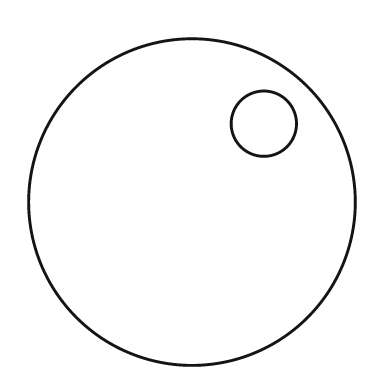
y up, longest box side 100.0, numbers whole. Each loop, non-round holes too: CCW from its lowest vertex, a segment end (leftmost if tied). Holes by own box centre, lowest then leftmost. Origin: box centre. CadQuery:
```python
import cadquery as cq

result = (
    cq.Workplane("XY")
    .moveTo(0.0, 0.0)
    .circle(50.0)
    .moveTo(22.0, 24.0)
    .circle(10.0)
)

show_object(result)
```